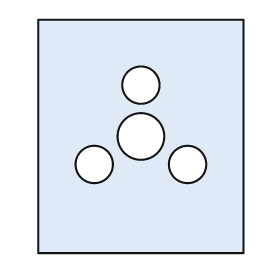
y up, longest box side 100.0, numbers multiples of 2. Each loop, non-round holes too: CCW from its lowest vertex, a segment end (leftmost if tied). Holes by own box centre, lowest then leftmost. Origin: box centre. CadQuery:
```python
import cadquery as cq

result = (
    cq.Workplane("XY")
    .moveTo(-44.0, -50.0)
    .lineTo(44.0, -50.0)
    .lineTo(44.0, 50.0)
    .lineTo(-44.0, 50.0)
    .close()
    .moveTo(-20.0, -12.0)
    .circle(8.0)
    .moveTo(20.0, -12.0)
    .circle(8.0)
    .moveTo(0.0, 0.0)
    .circle(10.0)
    .moveTo(0.0, 22.0)
    .circle(8.0)
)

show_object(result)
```